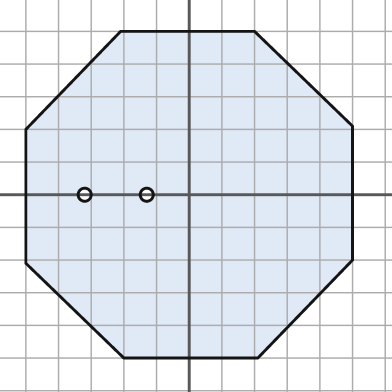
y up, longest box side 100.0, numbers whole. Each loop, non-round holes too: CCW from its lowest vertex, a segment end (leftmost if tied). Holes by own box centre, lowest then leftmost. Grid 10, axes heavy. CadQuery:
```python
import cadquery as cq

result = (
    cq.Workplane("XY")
    .moveTo(-20.0, -50.0)
    .lineTo(21.0, -50.0)
    .lineTo(50.0, -20.0)
    .lineTo(50.0, 21.0)
    .lineTo(20.0, 50.0)
    .lineTo(-21.0, 50.0)
    .lineTo(-50.0, 20.0)
    .lineTo(-50.0, -21.0)
    .close()
    .moveTo(-32.0, 0.0)
    .circle(2.0)
    .moveTo(-13.0, 0.0)
    .circle(2.0)
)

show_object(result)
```